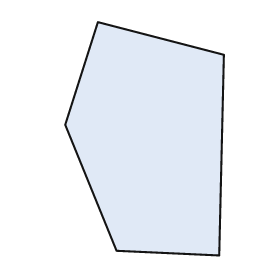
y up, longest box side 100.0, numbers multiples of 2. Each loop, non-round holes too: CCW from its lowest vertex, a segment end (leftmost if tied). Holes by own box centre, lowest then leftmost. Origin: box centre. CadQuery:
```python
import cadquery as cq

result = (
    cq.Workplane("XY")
    .moveTo(32.0, -50.0)
    .lineTo(34.0, 36.0)
    .lineTo(-20.0, 50.0)
    .lineTo(-34.0, 6.0)
    .lineTo(-12.0, -48.0)
    .close()
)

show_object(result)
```